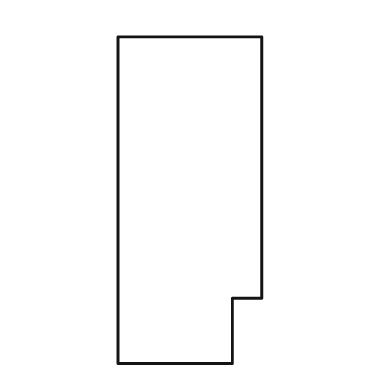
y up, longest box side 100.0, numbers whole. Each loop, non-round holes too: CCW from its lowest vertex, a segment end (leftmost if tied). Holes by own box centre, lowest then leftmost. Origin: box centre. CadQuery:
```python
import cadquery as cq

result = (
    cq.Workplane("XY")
    .moveTo(-22.0, -50.0)
    .lineTo(13.0, -50.0)
    .lineTo(13.0, -30.0)
    .lineTo(22.0, -30.0)
    .lineTo(22.0, 50.0)
    .lineTo(-22.0, 50.0)
    .close()
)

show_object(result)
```